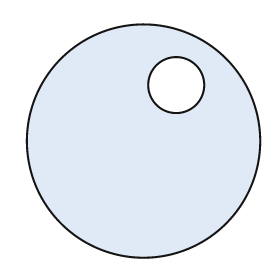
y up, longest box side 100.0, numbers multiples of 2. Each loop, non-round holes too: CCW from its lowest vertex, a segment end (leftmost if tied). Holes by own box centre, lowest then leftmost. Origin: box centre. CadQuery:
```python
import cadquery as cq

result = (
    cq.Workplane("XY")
    .moveTo(0.0, 0.0)
    .circle(50.0)
    .moveTo(14.0, 24.0)
    .circle(12.0)
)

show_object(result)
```